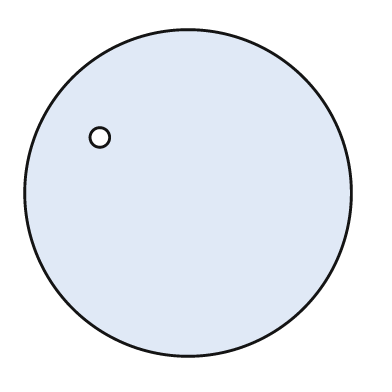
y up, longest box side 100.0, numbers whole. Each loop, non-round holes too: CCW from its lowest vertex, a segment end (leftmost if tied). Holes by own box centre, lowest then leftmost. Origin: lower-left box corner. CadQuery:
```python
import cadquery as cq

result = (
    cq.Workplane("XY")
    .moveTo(50.0, 50.0)
    .circle(50.0)
    .moveTo(23.0, 67.0)
    .circle(3.0)
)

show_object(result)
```